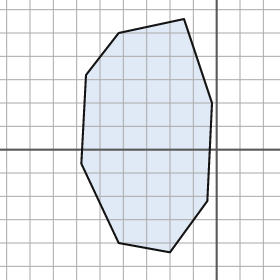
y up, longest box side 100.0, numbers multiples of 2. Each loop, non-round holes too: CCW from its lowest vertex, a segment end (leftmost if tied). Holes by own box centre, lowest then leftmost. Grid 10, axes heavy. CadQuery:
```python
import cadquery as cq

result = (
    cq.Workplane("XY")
    .moveTo(-20.0, -44.0)
    .lineTo(-4.0, -22.0)
    .lineTo(-2.0, 20.0)
    .lineTo(-14.0, 56.0)
    .lineTo(-42.0, 50.0)
    .lineTo(-56.0, 32.0)
    .lineTo(-58.0, -6.0)
    .lineTo(-42.0, -40.0)
    .close()
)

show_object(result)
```